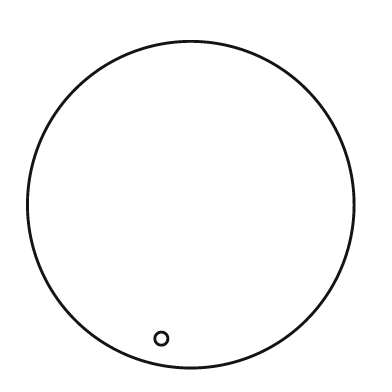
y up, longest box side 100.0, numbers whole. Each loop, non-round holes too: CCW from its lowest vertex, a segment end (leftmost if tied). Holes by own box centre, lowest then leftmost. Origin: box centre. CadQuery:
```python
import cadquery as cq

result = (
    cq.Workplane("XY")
    .moveTo(0.0, 0.0)
    .circle(50.0)
    .moveTo(-9.0, -41.0)
    .circle(2.0)
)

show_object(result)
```